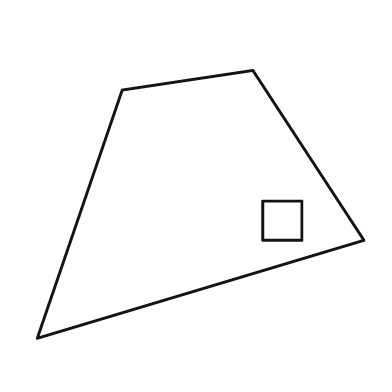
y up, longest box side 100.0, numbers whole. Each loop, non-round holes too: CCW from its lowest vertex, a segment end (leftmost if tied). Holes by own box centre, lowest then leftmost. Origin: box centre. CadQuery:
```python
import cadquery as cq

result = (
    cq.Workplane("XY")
    .moveTo(-50.0, -41.0)
    .lineTo(50.0, -11.0)
    .lineTo(16.0, 41.0)
    .lineTo(-24.0, 35.0)
    .close()
    .moveTo(19.0, -11.0)
    .lineTo(31.0, -11.0)
    .lineTo(31.0, 1.0)
    .lineTo(19.0, 1.0)
    .close()
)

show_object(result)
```